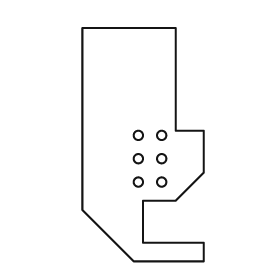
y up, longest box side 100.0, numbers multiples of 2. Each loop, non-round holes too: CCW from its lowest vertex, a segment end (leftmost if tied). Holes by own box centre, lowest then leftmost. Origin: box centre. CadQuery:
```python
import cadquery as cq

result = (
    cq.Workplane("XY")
    .moveTo(-4.0, -50.0)
    .lineTo(26.0, -50.0)
    .lineTo(26.0, -42.0)
    .lineTo(0.0, -42.0)
    .lineTo(0.0, -24.0)
    .lineTo(14.0, -24.0)
    .lineTo(26.0, -12.0)
    .lineTo(26.0, 6.0)
    .lineTo(14.0, 6.0)
    .lineTo(14.0, 50.0)
    .lineTo(-26.0, 50.0)
    .lineTo(-26.0, -28.0)
    .close()
    .moveTo(-2.0, -16.0)
    .circle(2.0)
    .moveTo(8.0, -16.0)
    .circle(2.0)
    .moveTo(-2.0, -6.0)
    .circle(2.0)
    .moveTo(8.0, -6.0)
    .circle(2.0)
    .moveTo(-2.0, 4.0)
    .circle(2.0)
    .moveTo(8.0, 4.0)
    .circle(2.0)
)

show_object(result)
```